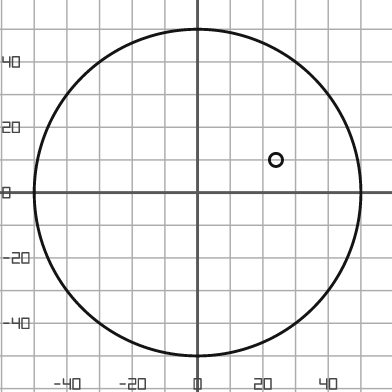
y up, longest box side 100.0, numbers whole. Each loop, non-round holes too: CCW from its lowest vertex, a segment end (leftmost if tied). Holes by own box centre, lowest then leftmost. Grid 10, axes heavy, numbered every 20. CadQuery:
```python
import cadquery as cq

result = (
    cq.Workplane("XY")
    .moveTo(0.0, 0.0)
    .circle(50.0)
    .moveTo(24.0, 10.0)
    .circle(2.0)
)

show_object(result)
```